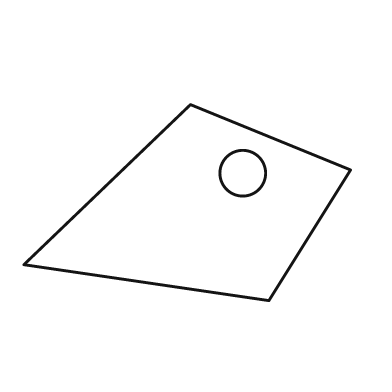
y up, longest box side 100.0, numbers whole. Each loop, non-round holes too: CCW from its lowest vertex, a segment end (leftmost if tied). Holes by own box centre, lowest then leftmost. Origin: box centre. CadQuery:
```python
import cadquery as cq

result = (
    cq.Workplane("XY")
    .moveTo(25.0, -30.0)
    .lineTo(50.0, 10.0)
    .lineTo(1.0, 30.0)
    .lineTo(-50.0, -19.0)
    .close()
    .moveTo(17.0, 9.0)
    .circle(7.0)
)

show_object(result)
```